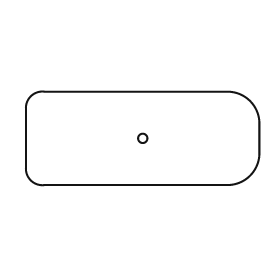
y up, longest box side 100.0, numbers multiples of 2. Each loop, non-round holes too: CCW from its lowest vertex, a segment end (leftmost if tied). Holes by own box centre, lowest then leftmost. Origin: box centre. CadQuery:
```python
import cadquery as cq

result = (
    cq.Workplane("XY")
    .moveTo(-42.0, -20.0)
    .lineTo(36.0, -20.0)
    .threePointArc((46.0, -16.0), (50.0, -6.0))
    .lineTo(50.0, 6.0)
    .threePointArc((46.0, 16.0), (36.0, 20.0))
    .lineTo(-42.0, 20.0)
    .threePointArc((-48.0, 18.0), (-50.0, 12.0))
    .lineTo(-50.0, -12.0)
    .threePointArc((-48.0, -18.0), (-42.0, -20.0))
    .close()
    .moveTo(0.0, 0.0)
    .circle(2.0)
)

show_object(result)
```